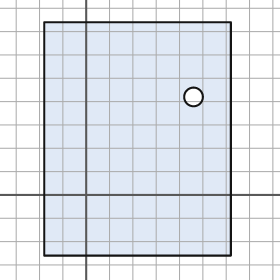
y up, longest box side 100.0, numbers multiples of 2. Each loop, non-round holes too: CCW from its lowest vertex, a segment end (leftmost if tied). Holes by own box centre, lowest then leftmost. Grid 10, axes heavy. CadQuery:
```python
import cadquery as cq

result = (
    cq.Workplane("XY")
    .moveTo(-18.0, -26.0)
    .lineTo(62.0, -26.0)
    .lineTo(62.0, 74.0)
    .lineTo(-18.0, 74.0)
    .close()
    .moveTo(46.0, 42.0)
    .circle(4.0)
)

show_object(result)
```